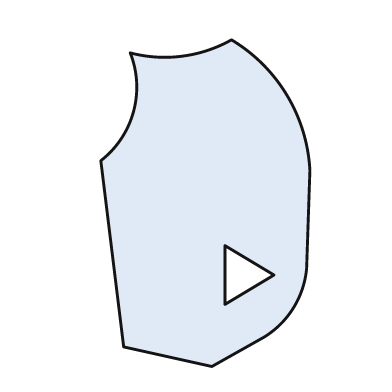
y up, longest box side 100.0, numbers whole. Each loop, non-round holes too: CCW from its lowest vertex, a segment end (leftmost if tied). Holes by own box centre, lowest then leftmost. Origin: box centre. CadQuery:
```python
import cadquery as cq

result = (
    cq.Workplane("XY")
    .moveTo(2.0, -50.0)
    .lineTo(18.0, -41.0)
    .threePointArc((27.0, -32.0), (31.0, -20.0))
    .lineTo(32.0, 10.0)
    .threePointArc((25.0, 33.0), (8.0, 50.0))
    .threePointArc((-7.0, 45.0), (-23.0, 46.0))
    .threePointArc((-22.0, 28.0), (-32.0, 13.0))
    .lineTo(-25.0, -44.0)
    .close()
    .moveTo(6.0, -31.0)
    .lineTo(21.0, -22.0)
    .lineTo(6.0, -13.0)
    .close()
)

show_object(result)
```